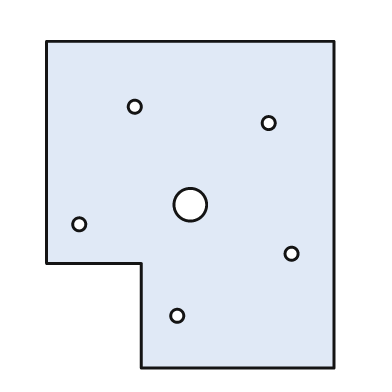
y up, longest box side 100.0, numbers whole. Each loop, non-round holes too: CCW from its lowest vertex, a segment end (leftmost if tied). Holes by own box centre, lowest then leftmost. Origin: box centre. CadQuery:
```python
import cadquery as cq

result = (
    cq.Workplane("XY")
    .moveTo(-15.0, -50.0)
    .lineTo(44.0, -50.0)
    .lineTo(44.0, 50.0)
    .lineTo(-44.0, 50.0)
    .lineTo(-44.0, -18.0)
    .lineTo(-15.0, -18.0)
    .close()
    .moveTo(-4.0, -34.0)
    .circle(2.0)
    .moveTo(31.0, -15.0)
    .circle(2.0)
    .moveTo(-34.0, -6.0)
    .circle(2.0)
    .moveTo(0.0, 0.0)
    .circle(5.0)
    .moveTo(24.0, 25.0)
    .circle(2.0)
    .moveTo(-17.0, 30.0)
    .circle(2.0)
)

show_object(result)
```